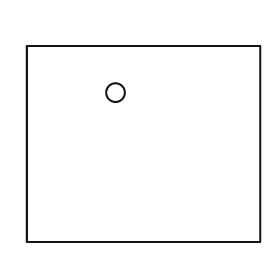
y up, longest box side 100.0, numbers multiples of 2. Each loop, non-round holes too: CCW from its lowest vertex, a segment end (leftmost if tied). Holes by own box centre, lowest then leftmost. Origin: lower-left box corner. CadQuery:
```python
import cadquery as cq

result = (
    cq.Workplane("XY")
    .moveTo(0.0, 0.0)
    .lineTo(100.0, 0.0)
    .lineTo(100.0, 84.0)
    .lineTo(0.0, 84.0)
    .close()
    .moveTo(38.0, 64.0)
    .circle(4.0)
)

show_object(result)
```